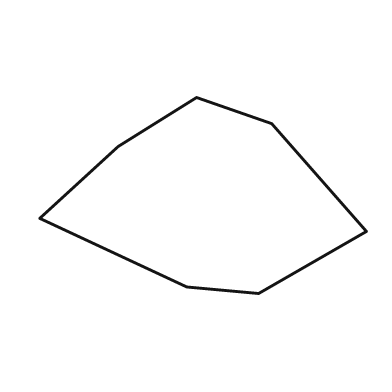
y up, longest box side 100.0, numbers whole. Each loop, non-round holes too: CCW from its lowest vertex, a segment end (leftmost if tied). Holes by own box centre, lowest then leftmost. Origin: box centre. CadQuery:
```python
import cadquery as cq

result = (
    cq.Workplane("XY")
    .moveTo(17.0, -30.0)
    .lineTo(50.0, -11.0)
    .lineTo(21.0, 22.0)
    .lineTo(-2.0, 30.0)
    .lineTo(-26.0, 15.0)
    .lineTo(-50.0, -7.0)
    .lineTo(-5.0, -28.0)
    .close()
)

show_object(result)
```